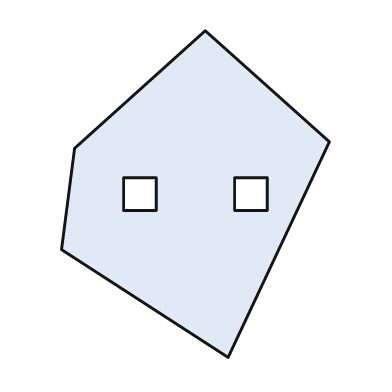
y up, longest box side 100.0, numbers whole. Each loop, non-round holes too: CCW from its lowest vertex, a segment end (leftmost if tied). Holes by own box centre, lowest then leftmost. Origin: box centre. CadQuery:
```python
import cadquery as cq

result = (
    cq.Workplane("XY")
    .moveTo(10.0, -50.0)
    .lineTo(41.0, 16.0)
    .lineTo(3.0, 50.0)
    .lineTo(-37.0, 14.0)
    .lineTo(-41.0, -17.0)
    .close()
    .moveTo(-22.0, -5.0)
    .lineTo(-12.0, -5.0)
    .lineTo(-12.0, 5.0)
    .lineTo(-22.0, 5.0)
    .close()
    .moveTo(12.0, -5.0)
    .lineTo(22.0, -5.0)
    .lineTo(22.0, 5.0)
    .lineTo(12.0, 5.0)
    .close()
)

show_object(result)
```